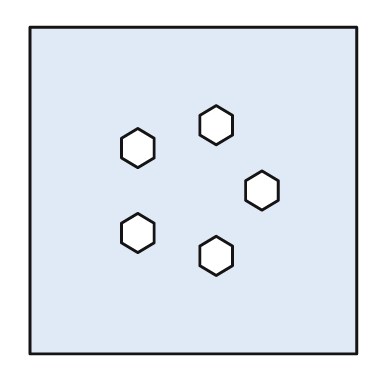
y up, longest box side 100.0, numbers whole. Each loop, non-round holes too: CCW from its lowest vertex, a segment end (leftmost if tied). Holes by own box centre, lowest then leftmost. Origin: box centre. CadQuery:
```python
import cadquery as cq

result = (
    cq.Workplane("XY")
    .moveTo(-50.0, -50.0)
    .lineTo(50.0, -50.0)
    .lineTo(50.0, 50.0)
    .lineTo(-50.0, 50.0)
    .close()
    .moveTo(7.0, -26.0)
    .lineTo(12.0, -23.0)
    .lineTo(12.0, -17.0)
    .lineTo(7.0, -14.0)
    .lineTo(2.0, -17.0)
    .lineTo(2.0, -23.0)
    .close()
    .moveTo(-17.0, -19.0)
    .lineTo(-12.0, -16.0)
    .lineTo(-12.0, -10.0)
    .lineTo(-17.0, -7.0)
    .lineTo(-22.0, -10.0)
    .lineTo(-22.0, -16.0)
    .close()
    .moveTo(21.0, -6.0)
    .lineTo(26.0, -3.0)
    .lineTo(26.0, 3.0)
    .lineTo(21.0, 6.0)
    .lineTo(16.0, 3.0)
    .lineTo(16.0, -3.0)
    .close()
    .moveTo(-17.0, 7.0)
    .lineTo(-12.0, 10.0)
    .lineTo(-12.0, 16.0)
    .lineTo(-17.0, 19.0)
    .lineTo(-22.0, 16.0)
    .lineTo(-22.0, 10.0)
    .close()
    .moveTo(7.0, 14.0)
    .lineTo(12.0, 17.0)
    .lineTo(12.0, 23.0)
    .lineTo(7.0, 26.0)
    .lineTo(2.0, 23.0)
    .lineTo(2.0, 17.0)
    .close()
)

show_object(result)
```